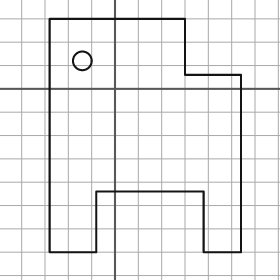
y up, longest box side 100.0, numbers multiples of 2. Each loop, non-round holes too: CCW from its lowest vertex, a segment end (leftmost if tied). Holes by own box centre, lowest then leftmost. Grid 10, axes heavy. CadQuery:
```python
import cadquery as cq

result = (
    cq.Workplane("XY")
    .moveTo(-28.0, -70.0)
    .lineTo(-8.0, -70.0)
    .lineTo(-8.0, -44.0)
    .lineTo(38.0, -44.0)
    .lineTo(38.0, -70.0)
    .lineTo(54.0, -70.0)
    .lineTo(54.0, 6.0)
    .lineTo(30.0, 6.0)
    .lineTo(30.0, 30.0)
    .lineTo(-28.0, 30.0)
    .close()
    .moveTo(-14.0, 12.0)
    .circle(4.0)
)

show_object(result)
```